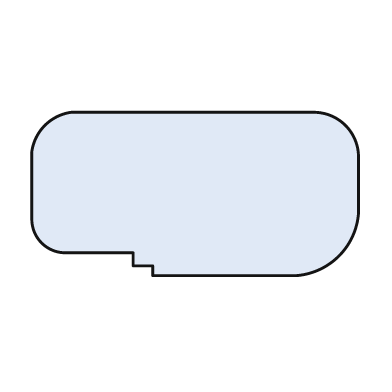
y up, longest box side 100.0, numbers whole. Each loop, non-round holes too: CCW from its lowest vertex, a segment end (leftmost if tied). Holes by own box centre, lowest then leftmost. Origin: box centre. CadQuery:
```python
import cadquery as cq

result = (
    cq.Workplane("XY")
    .moveTo(-13.0, -25.0)
    .lineTo(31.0, -25.0)
    .threePointArc((44.0, -19.0), (50.0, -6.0))
    .lineTo(50.0, 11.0)
    .threePointArc((46.0, 21.0), (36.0, 25.0))
    .lineTo(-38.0, 25.0)
    .threePointArc((-46.0, 21.0), (-50.0, 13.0))
    .lineTo(-50.0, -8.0)
    .threePointArc((-47.0, -15.0), (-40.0, -18.0))
    .lineTo(-19.0, -18.0)
    .lineTo(-19.0, -22.0)
    .lineTo(-13.0, -22.0)
    .close()
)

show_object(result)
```